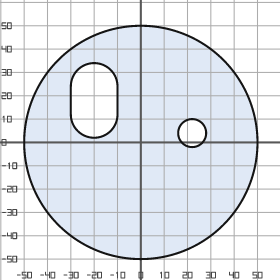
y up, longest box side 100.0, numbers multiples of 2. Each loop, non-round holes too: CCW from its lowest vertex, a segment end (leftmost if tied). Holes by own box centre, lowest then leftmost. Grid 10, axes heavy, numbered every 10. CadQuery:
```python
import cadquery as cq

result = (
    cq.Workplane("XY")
    .moveTo(0.0, 0.0)
    .circle(50.0)
    .moveTo(22.0, 4.0)
    .circle(6.0)
    .moveTo(-30.0, 12.0)
    .threePointArc((-20.0, 2.0), (-10.0, 12.0))
    .lineTo(-10.0, 24.0)
    .threePointArc((-20.0, 34.0), (-30.0, 24.0))
    .close()
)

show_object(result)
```